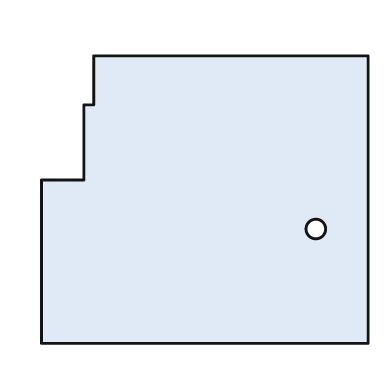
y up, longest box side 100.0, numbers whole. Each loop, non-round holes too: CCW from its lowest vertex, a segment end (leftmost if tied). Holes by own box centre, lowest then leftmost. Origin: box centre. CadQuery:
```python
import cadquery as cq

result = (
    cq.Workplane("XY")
    .moveTo(-50.0, -44.0)
    .lineTo(50.0, -44.0)
    .lineTo(50.0, 44.0)
    .lineTo(-34.0, 44.0)
    .lineTo(-34.0, 29.0)
    .lineTo(-37.0, 29.0)
    .lineTo(-37.0, 6.0)
    .lineTo(-50.0, 6.0)
    .close()
    .moveTo(34.0, -9.0)
    .circle(3.0)
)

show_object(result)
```